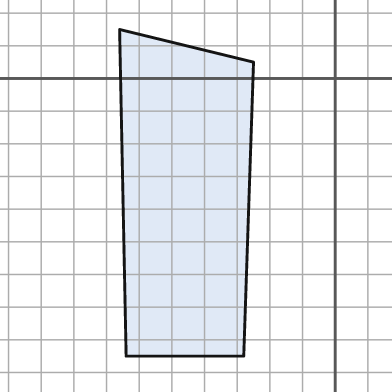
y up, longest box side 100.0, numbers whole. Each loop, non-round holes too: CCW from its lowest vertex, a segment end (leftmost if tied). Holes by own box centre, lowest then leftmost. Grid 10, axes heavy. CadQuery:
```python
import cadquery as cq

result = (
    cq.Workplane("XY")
    .moveTo(-64.0, -85.0)
    .lineTo(-28.0, -85.0)
    .lineTo(-25.0, 5.0)
    .lineTo(-66.0, 15.0)
    .close()
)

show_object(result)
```